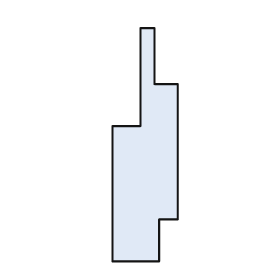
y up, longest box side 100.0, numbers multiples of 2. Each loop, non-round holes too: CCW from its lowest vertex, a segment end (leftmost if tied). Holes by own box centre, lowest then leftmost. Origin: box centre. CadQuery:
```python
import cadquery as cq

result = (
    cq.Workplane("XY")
    .moveTo(-14.0, -50.0)
    .lineTo(6.0, -50.0)
    .lineTo(6.0, -32.0)
    .lineTo(14.0, -32.0)
    .lineTo(14.0, 26.0)
    .lineTo(4.0, 26.0)
    .lineTo(4.0, 50.0)
    .lineTo(-2.0, 50.0)
    .lineTo(-2.0, 8.0)
    .lineTo(-14.0, 8.0)
    .close()
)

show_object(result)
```